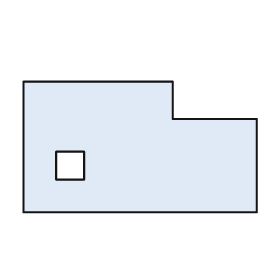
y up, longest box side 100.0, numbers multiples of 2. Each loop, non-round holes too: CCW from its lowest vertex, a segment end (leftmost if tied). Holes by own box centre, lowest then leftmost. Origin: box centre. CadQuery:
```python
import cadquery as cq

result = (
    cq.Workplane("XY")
    .moveTo(-50.0, -28.0)
    .lineTo(50.0, -28.0)
    .lineTo(50.0, 12.0)
    .lineTo(14.0, 12.0)
    .lineTo(14.0, 28.0)
    .lineTo(-50.0, 28.0)
    .close()
    .moveTo(-36.0, -14.0)
    .lineTo(-24.0, -14.0)
    .lineTo(-24.0, -2.0)
    .lineTo(-36.0, -2.0)
    .close()
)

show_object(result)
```